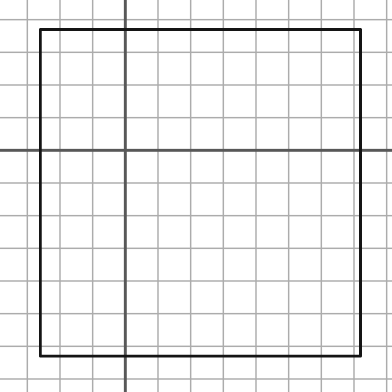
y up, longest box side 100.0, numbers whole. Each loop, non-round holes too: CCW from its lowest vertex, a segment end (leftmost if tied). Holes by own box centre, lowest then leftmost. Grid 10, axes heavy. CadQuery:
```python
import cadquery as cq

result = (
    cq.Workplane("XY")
    .moveTo(-26.0, -63.0)
    .lineTo(72.0, -63.0)
    .lineTo(72.0, 37.0)
    .lineTo(-26.0, 37.0)
    .close()
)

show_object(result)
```